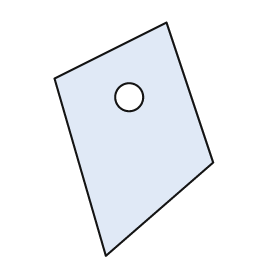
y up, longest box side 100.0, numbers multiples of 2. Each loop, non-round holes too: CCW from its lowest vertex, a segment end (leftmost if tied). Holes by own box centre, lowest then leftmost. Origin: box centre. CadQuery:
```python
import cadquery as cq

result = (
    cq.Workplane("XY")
    .moveTo(-12.0, -50.0)
    .lineTo(34.0, -10.0)
    .lineTo(14.0, 50.0)
    .lineTo(-34.0, 26.0)
    .close()
    .moveTo(-2.0, 18.0)
    .circle(6.0)
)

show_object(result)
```